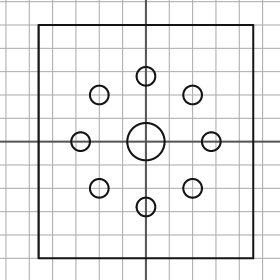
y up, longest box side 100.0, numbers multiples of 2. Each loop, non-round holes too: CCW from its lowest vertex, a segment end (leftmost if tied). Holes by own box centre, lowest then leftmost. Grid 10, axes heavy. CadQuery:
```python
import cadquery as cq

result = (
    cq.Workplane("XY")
    .moveTo(-46.0, -50.0)
    .lineTo(46.0, -50.0)
    .lineTo(46.0, 50.0)
    .lineTo(-46.0, 50.0)
    .close()
    .moveTo(0.0, -28.0)
    .circle(4.0)
    .moveTo(-20.0, -20.0)
    .circle(4.0)
    .moveTo(20.0, -20.0)
    .circle(4.0)
    .moveTo(-28.0, 0.0)
    .circle(4.0)
    .moveTo(0.0, 0.0)
    .circle(8.0)
    .moveTo(28.0, 0.0)
    .circle(4.0)
    .moveTo(-20.0, 20.0)
    .circle(4.0)
    .moveTo(20.0, 20.0)
    .circle(4.0)
    .moveTo(0.0, 28.0)
    .circle(4.0)
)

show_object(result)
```